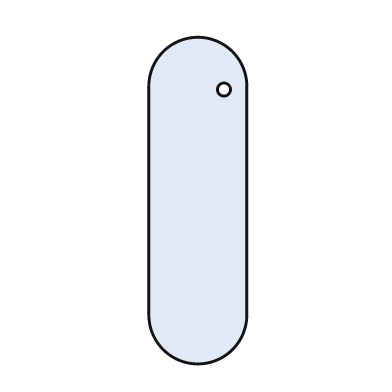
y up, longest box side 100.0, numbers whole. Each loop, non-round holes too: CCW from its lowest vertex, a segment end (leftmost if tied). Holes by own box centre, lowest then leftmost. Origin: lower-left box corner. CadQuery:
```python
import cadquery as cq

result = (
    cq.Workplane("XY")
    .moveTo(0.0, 15.0)
    .threePointArc((15.0, 0.0), (30.0, 15.0))
    .lineTo(30.0, 85.0)
    .threePointArc((15.0, 100.0), (0.0, 85.0))
    .close()
    .moveTo(23.0, 84.0)
    .circle(2.0)
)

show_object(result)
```